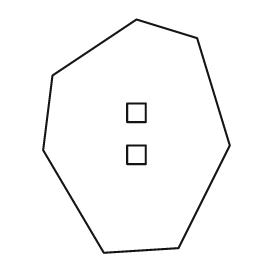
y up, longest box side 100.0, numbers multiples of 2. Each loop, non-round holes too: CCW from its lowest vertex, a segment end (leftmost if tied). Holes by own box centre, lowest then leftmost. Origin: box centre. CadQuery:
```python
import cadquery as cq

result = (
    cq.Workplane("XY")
    .moveTo(-14.0, -50.0)
    .lineTo(18.0, -48.0)
    .lineTo(40.0, -4.0)
    .lineTo(26.0, 42.0)
    .lineTo(0.0, 50.0)
    .lineTo(-36.0, 26.0)
    .lineTo(-40.0, -6.0)
    .close()
    .moveTo(-4.0, -12.0)
    .lineTo(4.0, -12.0)
    .lineTo(4.0, -4.0)
    .lineTo(-4.0, -4.0)
    .close()
    .moveTo(-4.0, 6.0)
    .lineTo(4.0, 6.0)
    .lineTo(4.0, 14.0)
    .lineTo(-4.0, 14.0)
    .close()
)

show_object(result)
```